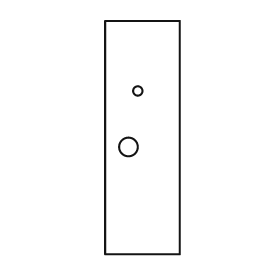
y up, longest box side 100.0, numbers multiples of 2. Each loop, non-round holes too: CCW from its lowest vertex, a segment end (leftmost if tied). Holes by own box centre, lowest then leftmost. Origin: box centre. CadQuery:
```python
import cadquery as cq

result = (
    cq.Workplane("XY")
    .moveTo(-16.0, -50.0)
    .lineTo(16.0, -50.0)
    .lineTo(16.0, 50.0)
    .lineTo(-16.0, 50.0)
    .close()
    .moveTo(-6.0, -4.0)
    .circle(4.0)
    .moveTo(-2.0, 20.0)
    .circle(2.0)
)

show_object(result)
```